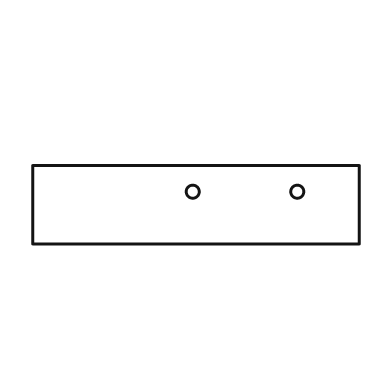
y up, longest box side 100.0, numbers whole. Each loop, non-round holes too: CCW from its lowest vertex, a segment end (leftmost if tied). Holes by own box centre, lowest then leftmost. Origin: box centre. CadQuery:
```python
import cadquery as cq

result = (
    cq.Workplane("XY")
    .moveTo(-50.0, -12.0)
    .lineTo(50.0, -12.0)
    .lineTo(50.0, 12.0)
    .lineTo(-50.0, 12.0)
    .close()
    .moveTo(-1.0, 4.0)
    .circle(2.0)
    .moveTo(31.0, 4.0)
    .circle(2.0)
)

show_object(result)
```